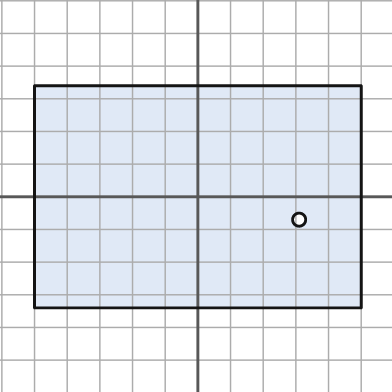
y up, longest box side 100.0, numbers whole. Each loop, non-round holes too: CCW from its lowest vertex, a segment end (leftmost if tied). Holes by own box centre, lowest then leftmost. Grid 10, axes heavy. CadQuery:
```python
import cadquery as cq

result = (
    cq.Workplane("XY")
    .moveTo(-50.0, -34.0)
    .lineTo(50.0, -34.0)
    .lineTo(50.0, 34.0)
    .lineTo(-50.0, 34.0)
    .close()
    .moveTo(31.0, -7.0)
    .circle(2.0)
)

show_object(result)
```